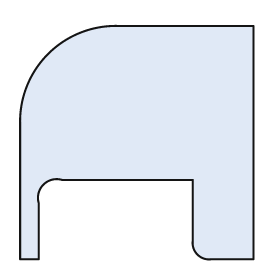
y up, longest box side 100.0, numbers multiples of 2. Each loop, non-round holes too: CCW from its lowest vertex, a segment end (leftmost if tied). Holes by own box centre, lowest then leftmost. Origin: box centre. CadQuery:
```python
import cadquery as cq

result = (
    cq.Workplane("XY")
    .moveTo(-50.0, -50.0)
    .lineTo(-42.0, -50.0)
    .lineTo(-42.0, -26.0)
    .threePointArc((-40.0, -18.0), (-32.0, -16.0))
    .lineTo(24.0, -16.0)
    .lineTo(24.0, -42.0)
    .threePointArc((26.0, -48.0), (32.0, -50.0))
    .lineTo(50.0, -50.0)
    .lineTo(50.0, 50.0)
    .lineTo(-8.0, 50.0)
    .threePointArc((-38.0, 38.0), (-50.0, 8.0))
    .close()
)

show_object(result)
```